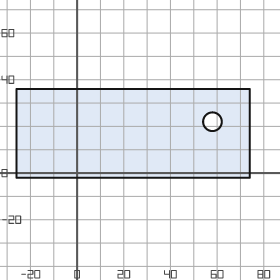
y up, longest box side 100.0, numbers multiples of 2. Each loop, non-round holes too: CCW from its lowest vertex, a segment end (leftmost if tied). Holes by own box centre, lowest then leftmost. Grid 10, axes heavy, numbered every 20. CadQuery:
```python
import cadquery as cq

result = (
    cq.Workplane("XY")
    .moveTo(-26.0, -2.0)
    .lineTo(74.0, -2.0)
    .lineTo(74.0, 36.0)
    .lineTo(-26.0, 36.0)
    .close()
    .moveTo(58.0, 22.0)
    .circle(4.0)
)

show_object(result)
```